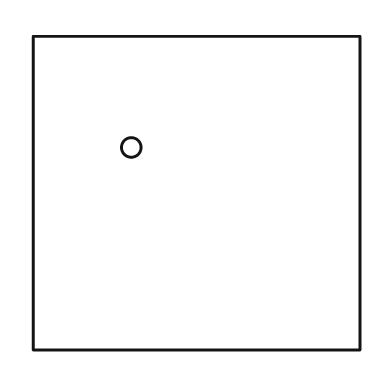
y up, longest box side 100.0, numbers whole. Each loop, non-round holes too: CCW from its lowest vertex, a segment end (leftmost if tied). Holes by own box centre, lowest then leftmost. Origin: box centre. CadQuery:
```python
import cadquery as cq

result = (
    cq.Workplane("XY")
    .moveTo(-50.0, -48.0)
    .lineTo(50.0, -48.0)
    .lineTo(50.0, 48.0)
    .lineTo(-50.0, 48.0)
    .close()
    .moveTo(-20.0, 14.0)
    .circle(3.0)
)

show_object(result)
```